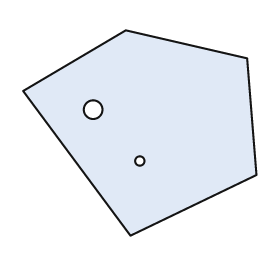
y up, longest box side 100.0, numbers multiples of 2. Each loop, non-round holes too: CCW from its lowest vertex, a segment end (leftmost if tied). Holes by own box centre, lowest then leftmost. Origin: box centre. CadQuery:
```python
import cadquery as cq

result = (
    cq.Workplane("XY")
    .moveTo(-4.0, -44.0)
    .lineTo(50.0, -18.0)
    .lineTo(46.0, 32.0)
    .lineTo(-6.0, 44.0)
    .lineTo(-50.0, 18.0)
    .close()
    .moveTo(0.0, -12.0)
    .circle(2.0)
    .moveTo(-20.0, 10.0)
    .circle(4.0)
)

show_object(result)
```